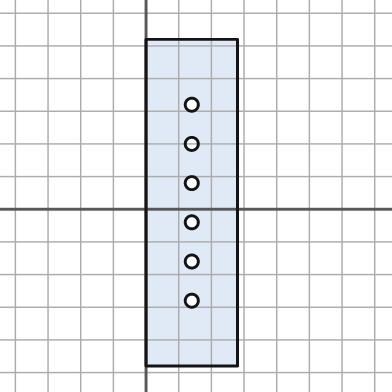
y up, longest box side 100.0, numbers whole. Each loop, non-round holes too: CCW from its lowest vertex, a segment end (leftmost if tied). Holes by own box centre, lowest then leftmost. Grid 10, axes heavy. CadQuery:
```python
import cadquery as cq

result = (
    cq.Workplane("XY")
    .moveTo(0.0, -48.0)
    .lineTo(28.0, -48.0)
    .lineTo(28.0, 52.0)
    .lineTo(0.0, 52.0)
    .close()
    .moveTo(14.0, -28.0)
    .circle(2.0)
    .moveTo(14.0, -16.0)
    .circle(2.0)
    .moveTo(14.0, -4.0)
    .circle(2.0)
    .moveTo(14.0, 8.0)
    .circle(2.0)
    .moveTo(14.0, 20.0)
    .circle(2.0)
    .moveTo(14.0, 32.0)
    .circle(2.0)
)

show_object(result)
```